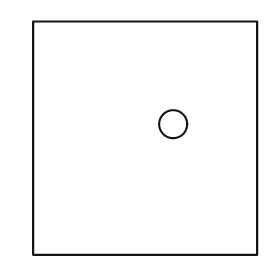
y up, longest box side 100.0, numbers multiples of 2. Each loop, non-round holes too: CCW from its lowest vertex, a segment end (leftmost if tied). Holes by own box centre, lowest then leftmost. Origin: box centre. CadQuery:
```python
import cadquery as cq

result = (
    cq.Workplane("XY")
    .moveTo(-48.0, -50.0)
    .lineTo(48.0, -50.0)
    .lineTo(48.0, 50.0)
    .lineTo(-48.0, 50.0)
    .close()
    .moveTo(12.0, 6.0)
    .circle(6.0)
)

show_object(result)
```